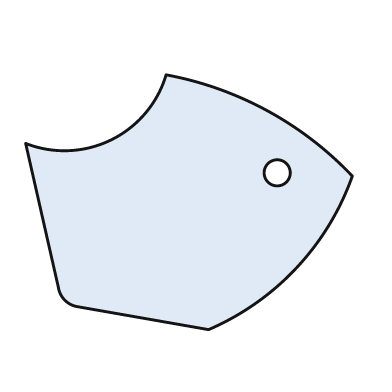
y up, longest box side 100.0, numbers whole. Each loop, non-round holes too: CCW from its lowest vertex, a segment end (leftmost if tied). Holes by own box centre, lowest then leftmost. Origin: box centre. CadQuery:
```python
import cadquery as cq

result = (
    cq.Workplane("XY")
    .moveTo(6.0, -39.0)
    .threePointArc((33.0, -20.0), (50.0, 8.0))
    .threePointArc((24.0, 28.0), (-7.0, 39.0))
    .threePointArc((-24.0, 19.0), (-50.0, 18.0))
    .lineTo(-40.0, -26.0)
    .threePointArc((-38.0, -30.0), (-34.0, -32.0))
    .close()
    .moveTo(27.0, 9.0)
    .circle(4.0)
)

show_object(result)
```